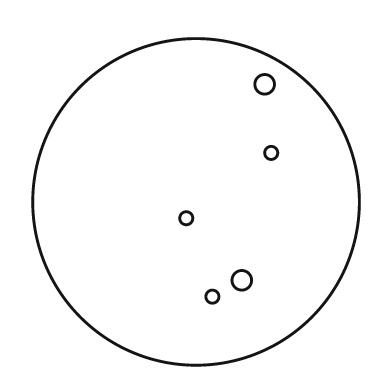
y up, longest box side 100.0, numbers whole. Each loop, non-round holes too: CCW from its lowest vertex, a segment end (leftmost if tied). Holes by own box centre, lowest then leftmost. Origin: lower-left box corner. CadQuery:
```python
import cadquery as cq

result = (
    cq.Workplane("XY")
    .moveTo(50.0, 50.0)
    .circle(50.0)
    .moveTo(55.0, 21.0)
    .circle(2.0)
    .moveTo(64.0, 26.0)
    .circle(3.0)
    .moveTo(47.0, 45.0)
    .circle(2.0)
    .moveTo(73.0, 65.0)
    .circle(2.0)
    .moveTo(71.0, 86.0)
    .circle(3.0)
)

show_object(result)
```